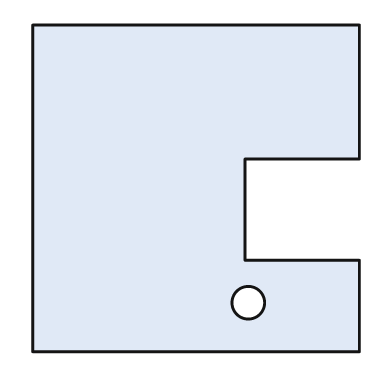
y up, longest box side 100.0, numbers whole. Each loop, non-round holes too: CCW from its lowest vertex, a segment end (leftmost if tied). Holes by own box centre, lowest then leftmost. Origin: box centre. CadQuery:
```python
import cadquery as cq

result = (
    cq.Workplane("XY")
    .moveTo(-50.0, -50.0)
    .lineTo(50.0, -50.0)
    .lineTo(50.0, -22.0)
    .lineTo(15.0, -22.0)
    .lineTo(15.0, 9.0)
    .lineTo(50.0, 9.0)
    .lineTo(50.0, 50.0)
    .lineTo(-50.0, 50.0)
    .close()
    .moveTo(16.0, -35.0)
    .circle(5.0)
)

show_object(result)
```